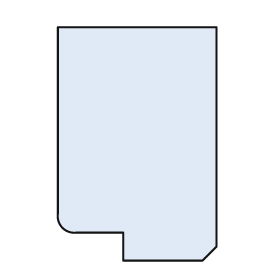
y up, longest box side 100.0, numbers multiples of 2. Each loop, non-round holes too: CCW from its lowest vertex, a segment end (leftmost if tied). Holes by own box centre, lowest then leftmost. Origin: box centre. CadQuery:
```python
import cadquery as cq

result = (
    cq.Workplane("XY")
    .moveTo(-6.0, -50.0)
    .lineTo(28.0, -50.0)
    .lineTo(34.0, -44.0)
    .lineTo(34.0, 50.0)
    .lineTo(-34.0, 50.0)
    .lineTo(-34.0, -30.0)
    .threePointArc((-32.0, -36.0), (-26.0, -38.0))
    .lineTo(-6.0, -38.0)
    .close()
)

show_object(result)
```